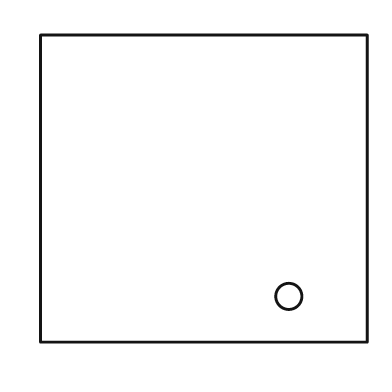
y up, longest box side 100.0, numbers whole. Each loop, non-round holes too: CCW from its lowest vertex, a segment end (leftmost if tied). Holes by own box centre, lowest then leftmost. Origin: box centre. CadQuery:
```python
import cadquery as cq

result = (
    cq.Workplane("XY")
    .moveTo(-50.0, -47.0)
    .lineTo(50.0, -47.0)
    .lineTo(50.0, 47.0)
    .lineTo(-50.0, 47.0)
    .close()
    .moveTo(26.0, -33.0)
    .circle(4.0)
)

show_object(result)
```